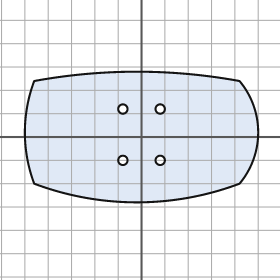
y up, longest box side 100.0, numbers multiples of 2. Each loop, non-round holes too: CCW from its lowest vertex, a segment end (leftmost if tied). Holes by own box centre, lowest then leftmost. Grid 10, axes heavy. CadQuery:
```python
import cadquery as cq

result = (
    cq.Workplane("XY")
    .moveTo(-46.0, -20.0)
    .threePointArc((-2.0, -28.0), (42.0, -20.0))
    .threePointArc((50.0, 2.0), (42.0, 24.0))
    .threePointArc((-2.0, 28.0), (-46.0, 24.0))
    .threePointArc((-50.0, 2.0), (-46.0, -20.0))
    .close()
    .moveTo(-8.0, -10.0)
    .circle(2.0)
    .moveTo(8.0, -10.0)
    .circle(2.0)
    .moveTo(-8.0, 12.0)
    .circle(2.0)
    .moveTo(8.0, 12.0)
    .circle(2.0)
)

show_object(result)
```